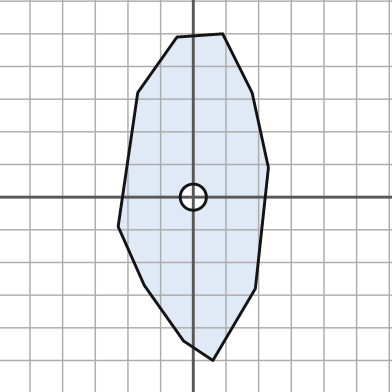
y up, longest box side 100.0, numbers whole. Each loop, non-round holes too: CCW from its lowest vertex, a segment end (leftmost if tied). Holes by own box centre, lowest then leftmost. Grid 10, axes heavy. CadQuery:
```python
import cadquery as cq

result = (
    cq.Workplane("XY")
    .moveTo(6.0, -50.0)
    .lineTo(19.0, -28.0)
    .lineTo(23.0, 9.0)
    .lineTo(18.0, 32.0)
    .lineTo(9.0, 50.0)
    .lineTo(-5.0, 49.0)
    .lineTo(-17.0, 32.0)
    .lineTo(-23.0, -9.0)
    .lineTo(-15.0, -27.0)
    .lineTo(-3.0, -44.0)
    .close()
    .moveTo(0.0, 0.0)
    .circle(4.0)
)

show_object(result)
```